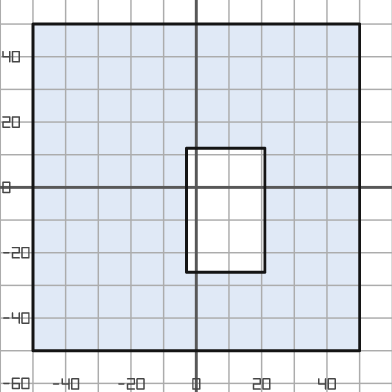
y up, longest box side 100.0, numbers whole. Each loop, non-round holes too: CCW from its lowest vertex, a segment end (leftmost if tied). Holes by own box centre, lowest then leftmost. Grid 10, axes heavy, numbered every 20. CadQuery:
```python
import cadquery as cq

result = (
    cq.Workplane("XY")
    .moveTo(-50.0, -50.0)
    .lineTo(50.0, -50.0)
    .lineTo(50.0, 50.0)
    .lineTo(-50.0, 50.0)
    .close()
    .moveTo(-3.0, -26.0)
    .lineTo(21.0, -26.0)
    .lineTo(21.0, 12.0)
    .lineTo(-3.0, 12.0)
    .close()
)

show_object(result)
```